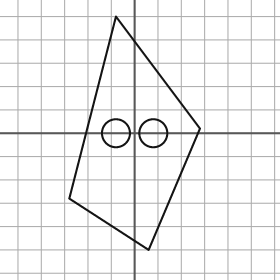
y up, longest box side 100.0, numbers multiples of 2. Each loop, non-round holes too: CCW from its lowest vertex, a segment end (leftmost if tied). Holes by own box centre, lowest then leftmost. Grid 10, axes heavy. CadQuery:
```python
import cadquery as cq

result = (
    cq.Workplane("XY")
    .moveTo(6.0, -50.0)
    .lineTo(28.0, 2.0)
    .lineTo(-8.0, 50.0)
    .lineTo(-28.0, -28.0)
    .close()
    .moveTo(-8.0, 0.0)
    .circle(6.0)
    .moveTo(8.0, 0.0)
    .circle(6.0)
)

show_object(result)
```